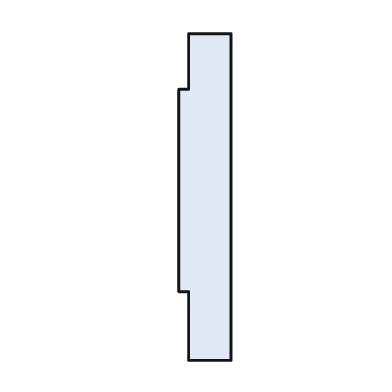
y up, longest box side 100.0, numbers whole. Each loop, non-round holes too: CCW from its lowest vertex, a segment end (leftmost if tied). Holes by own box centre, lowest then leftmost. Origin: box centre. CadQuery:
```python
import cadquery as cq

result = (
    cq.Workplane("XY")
    .moveTo(-5.0, -50.0)
    .lineTo(8.0, -50.0)
    .lineTo(8.0, 50.0)
    .lineTo(-5.0, 50.0)
    .lineTo(-5.0, 33.0)
    .lineTo(-8.0, 33.0)
    .lineTo(-8.0, -29.0)
    .lineTo(-5.0, -29.0)
    .close()
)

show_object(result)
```